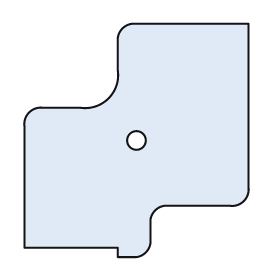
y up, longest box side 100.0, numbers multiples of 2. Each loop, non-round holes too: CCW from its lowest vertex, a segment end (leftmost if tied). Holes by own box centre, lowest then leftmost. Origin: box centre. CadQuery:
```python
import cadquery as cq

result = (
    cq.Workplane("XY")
    .moveTo(-8.0, -50.0)
    .lineTo(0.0, -50.0)
    .threePointArc((4.0, -48.0), (6.0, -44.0))
    .lineTo(6.0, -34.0)
    .threePointArc((8.0, -30.0), (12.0, -28.0))
    .lineTo(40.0, -28.0)
    .threePointArc((46.0, -26.0), (48.0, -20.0))
    .lineTo(48.0, 50.0)
    .lineTo(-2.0, 50.0)
    .threePointArc((-6.0, 48.0), (-8.0, 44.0))
    .lineTo(-8.0, 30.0)
    .threePointArc((-12.0, 18.0), (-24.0, 14.0))
    .lineTo(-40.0, 14.0)
    .threePointArc((-46.0, 12.0), (-48.0, 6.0))
    .lineTo(-48.0, -46.0)
    .lineTo(-8.0, -46.0)
    .close()
    .moveTo(0.0, 0.0)
    .circle(4.0)
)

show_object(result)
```